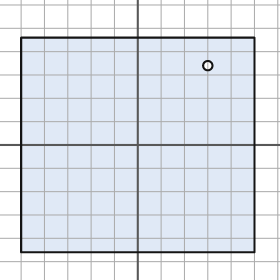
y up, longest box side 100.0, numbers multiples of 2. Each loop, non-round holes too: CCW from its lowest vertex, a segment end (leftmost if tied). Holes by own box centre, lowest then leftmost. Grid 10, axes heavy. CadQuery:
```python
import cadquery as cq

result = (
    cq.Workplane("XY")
    .moveTo(-50.0, -46.0)
    .lineTo(50.0, -46.0)
    .lineTo(50.0, 46.0)
    .lineTo(-50.0, 46.0)
    .close()
    .moveTo(30.0, 34.0)
    .circle(2.0)
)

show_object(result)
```